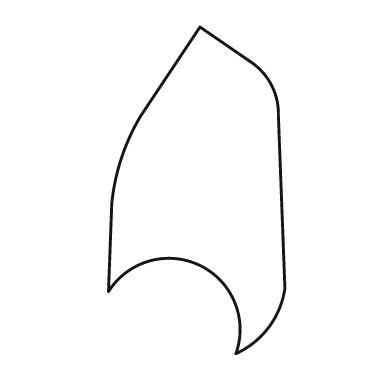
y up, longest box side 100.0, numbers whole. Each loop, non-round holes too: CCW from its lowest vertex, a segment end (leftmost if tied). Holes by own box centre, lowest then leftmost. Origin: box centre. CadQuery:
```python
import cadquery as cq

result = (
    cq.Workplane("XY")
    .moveTo(12.0, -50.0)
    .threePointArc((22.0, -42.0), (27.0, -30.0))
    .lineTo(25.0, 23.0)
    .threePointArc((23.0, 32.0), (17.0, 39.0))
    .lineTo(1.0, 50.0)
    .lineTo(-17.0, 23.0)
    .threePointArc((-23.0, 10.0), (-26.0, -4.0))
    .lineTo(-27.0, -31.0)
    .threePointArc((1.0, -23.0), (12.0, -50.0))
    .close()
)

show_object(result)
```